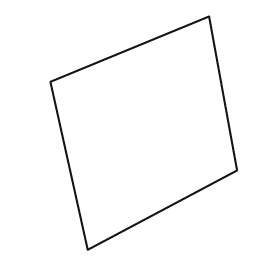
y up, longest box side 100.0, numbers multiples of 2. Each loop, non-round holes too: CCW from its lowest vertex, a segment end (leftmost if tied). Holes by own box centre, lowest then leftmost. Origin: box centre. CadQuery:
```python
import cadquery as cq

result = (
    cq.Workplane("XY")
    .moveTo(-24.0, -50.0)
    .lineTo(40.0, -16.0)
    .lineTo(28.0, 50.0)
    .lineTo(-40.0, 22.0)
    .close()
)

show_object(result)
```